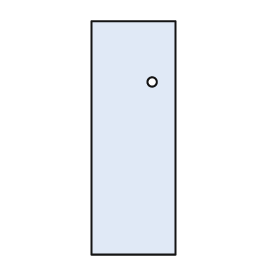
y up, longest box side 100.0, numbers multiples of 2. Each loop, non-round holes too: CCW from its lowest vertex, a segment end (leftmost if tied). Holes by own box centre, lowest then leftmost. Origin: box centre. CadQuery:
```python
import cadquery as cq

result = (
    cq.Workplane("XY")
    .moveTo(-18.0, -50.0)
    .lineTo(18.0, -50.0)
    .lineTo(18.0, 50.0)
    .lineTo(-18.0, 50.0)
    .close()
    .moveTo(8.0, 24.0)
    .circle(2.0)
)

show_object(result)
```